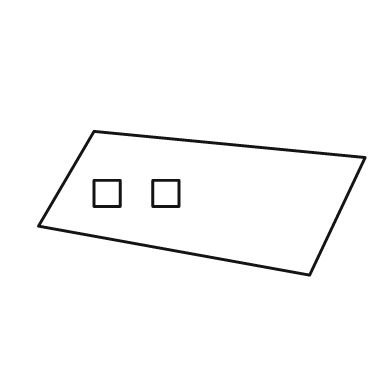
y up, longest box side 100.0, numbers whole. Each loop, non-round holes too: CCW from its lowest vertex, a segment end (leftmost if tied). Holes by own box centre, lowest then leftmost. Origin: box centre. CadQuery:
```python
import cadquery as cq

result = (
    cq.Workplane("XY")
    .moveTo(33.0, -22.0)
    .lineTo(50.0, 14.0)
    .lineTo(-33.0, 22.0)
    .lineTo(-50.0, -7.0)
    .close()
    .moveTo(-33.0, -1.0)
    .lineTo(-25.0, -1.0)
    .lineTo(-25.0, 7.0)
    .lineTo(-33.0, 7.0)
    .close()
    .moveTo(-15.0, -1.0)
    .lineTo(-7.0, -1.0)
    .lineTo(-7.0, 7.0)
    .lineTo(-15.0, 7.0)
    .close()
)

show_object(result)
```